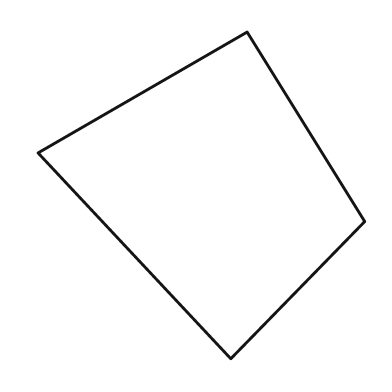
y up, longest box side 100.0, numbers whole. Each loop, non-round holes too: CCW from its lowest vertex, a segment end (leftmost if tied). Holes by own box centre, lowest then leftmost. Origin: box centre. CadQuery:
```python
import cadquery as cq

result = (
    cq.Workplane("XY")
    .moveTo(9.0, -50.0)
    .lineTo(50.0, -8.0)
    .lineTo(14.0, 50.0)
    .lineTo(-50.0, 13.0)
    .close()
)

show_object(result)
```